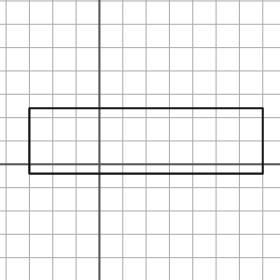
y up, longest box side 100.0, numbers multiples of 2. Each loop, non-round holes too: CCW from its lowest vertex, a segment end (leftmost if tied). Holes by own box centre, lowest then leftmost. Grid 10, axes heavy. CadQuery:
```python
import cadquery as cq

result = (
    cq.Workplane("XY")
    .moveTo(-30.0, -4.0)
    .lineTo(70.0, -4.0)
    .lineTo(70.0, 24.0)
    .lineTo(-30.0, 24.0)
    .close()
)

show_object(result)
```